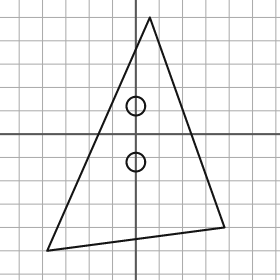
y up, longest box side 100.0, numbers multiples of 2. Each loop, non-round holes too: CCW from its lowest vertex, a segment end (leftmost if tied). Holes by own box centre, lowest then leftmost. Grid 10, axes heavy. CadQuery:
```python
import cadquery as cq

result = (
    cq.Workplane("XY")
    .moveTo(-38.0, -50.0)
    .lineTo(38.0, -40.0)
    .lineTo(6.0, 50.0)
    .close()
    .moveTo(0.0, -12.0)
    .circle(4.0)
    .moveTo(0.0, 12.0)
    .circle(4.0)
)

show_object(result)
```